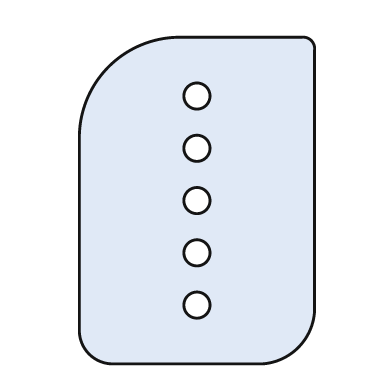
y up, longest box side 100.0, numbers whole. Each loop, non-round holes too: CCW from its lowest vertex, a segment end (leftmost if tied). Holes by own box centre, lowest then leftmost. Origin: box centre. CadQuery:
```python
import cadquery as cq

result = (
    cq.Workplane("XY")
    .moveTo(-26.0, -50.0)
    .lineTo(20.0, -50.0)
    .threePointArc((31.0, -45.0), (36.0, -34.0))
    .lineTo(36.0, 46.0)
    .threePointArc((35.0, 49.0), (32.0, 50.0))
    .lineTo(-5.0, 50.0)
    .threePointArc((-27.0, 41.0), (-36.0, 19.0))
    .lineTo(-36.0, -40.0)
    .threePointArc((-33.0, -47.0), (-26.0, -50.0))
    .close()
    .moveTo(0.0, -32.0)
    .circle(4.0)
    .moveTo(0.0, -16.0)
    .circle(4.0)
    .moveTo(0.0, 0.0)
    .circle(4.0)
    .moveTo(0.0, 16.0)
    .circle(4.0)
    .moveTo(0.0, 32.0)
    .circle(4.0)
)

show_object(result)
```